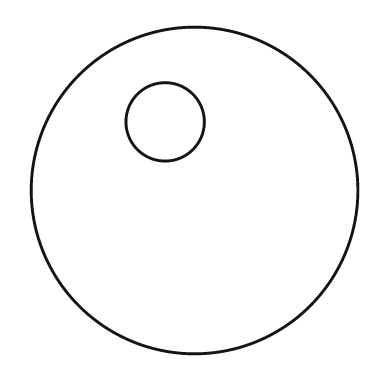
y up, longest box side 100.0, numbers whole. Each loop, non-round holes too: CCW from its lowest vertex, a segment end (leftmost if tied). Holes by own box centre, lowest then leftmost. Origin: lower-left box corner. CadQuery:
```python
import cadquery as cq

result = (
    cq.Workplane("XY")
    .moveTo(50.0, 50.0)
    .circle(50.0)
    .moveTo(41.0, 71.0)
    .circle(12.0)
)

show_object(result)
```